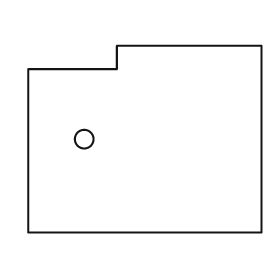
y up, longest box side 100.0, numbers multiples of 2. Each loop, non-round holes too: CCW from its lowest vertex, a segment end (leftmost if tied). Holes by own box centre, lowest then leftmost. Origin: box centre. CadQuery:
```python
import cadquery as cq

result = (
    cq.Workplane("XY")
    .moveTo(-50.0, -40.0)
    .lineTo(50.0, -40.0)
    .lineTo(50.0, 40.0)
    .lineTo(-12.0, 40.0)
    .lineTo(-12.0, 30.0)
    .lineTo(-50.0, 30.0)
    .close()
    .moveTo(-26.0, 0.0)
    .circle(4.0)
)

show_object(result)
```